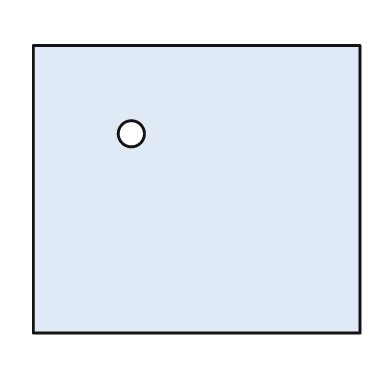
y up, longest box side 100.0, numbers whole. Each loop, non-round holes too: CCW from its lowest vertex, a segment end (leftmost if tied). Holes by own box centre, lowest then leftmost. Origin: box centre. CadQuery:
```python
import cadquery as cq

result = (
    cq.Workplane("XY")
    .moveTo(-50.0, -44.0)
    .lineTo(50.0, -44.0)
    .lineTo(50.0, 44.0)
    .lineTo(-50.0, 44.0)
    .close()
    .moveTo(-20.0, 17.0)
    .circle(4.0)
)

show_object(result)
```